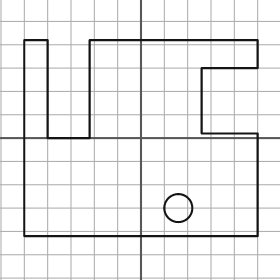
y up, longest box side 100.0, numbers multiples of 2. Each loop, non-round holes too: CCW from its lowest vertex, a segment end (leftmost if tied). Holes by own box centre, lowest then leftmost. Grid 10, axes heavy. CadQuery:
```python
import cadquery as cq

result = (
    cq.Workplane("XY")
    .moveTo(-50.0, -42.0)
    .lineTo(50.0, -42.0)
    .lineTo(50.0, 2.0)
    .lineTo(26.0, 2.0)
    .lineTo(26.0, 30.0)
    .lineTo(50.0, 30.0)
    .lineTo(50.0, 42.0)
    .lineTo(-22.0, 42.0)
    .lineTo(-22.0, 0.0)
    .lineTo(-40.0, 0.0)
    .lineTo(-40.0, 42.0)
    .lineTo(-50.0, 42.0)
    .close()
    .moveTo(16.0, -30.0)
    .circle(6.0)
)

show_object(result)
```